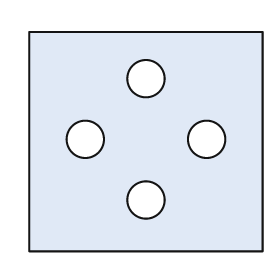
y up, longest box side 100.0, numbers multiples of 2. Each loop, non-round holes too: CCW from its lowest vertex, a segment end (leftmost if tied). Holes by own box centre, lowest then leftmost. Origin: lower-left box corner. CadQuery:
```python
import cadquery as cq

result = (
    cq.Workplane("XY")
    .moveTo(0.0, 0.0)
    .lineTo(100.0, 0.0)
    .lineTo(100.0, 94.0)
    .lineTo(0.0, 94.0)
    .close()
    .moveTo(50.0, 22.0)
    .circle(8.0)
    .moveTo(24.0, 48.0)
    .circle(8.0)
    .moveTo(76.0, 48.0)
    .circle(8.0)
    .moveTo(50.0, 74.0)
    .circle(8.0)
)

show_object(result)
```